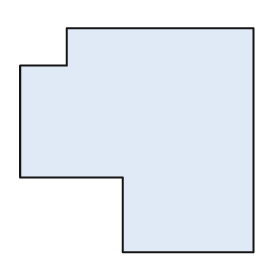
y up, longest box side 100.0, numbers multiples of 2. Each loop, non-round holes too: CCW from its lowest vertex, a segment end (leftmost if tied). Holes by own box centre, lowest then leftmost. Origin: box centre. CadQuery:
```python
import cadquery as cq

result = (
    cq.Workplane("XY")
    .moveTo(-6.0, -48.0)
    .lineTo(50.0, -48.0)
    .lineTo(50.0, 48.0)
    .lineTo(-30.0, 48.0)
    .lineTo(-30.0, 32.0)
    .lineTo(-50.0, 32.0)
    .lineTo(-50.0, -16.0)
    .lineTo(-6.0, -16.0)
    .close()
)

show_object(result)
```